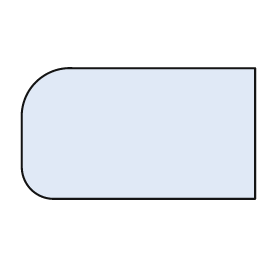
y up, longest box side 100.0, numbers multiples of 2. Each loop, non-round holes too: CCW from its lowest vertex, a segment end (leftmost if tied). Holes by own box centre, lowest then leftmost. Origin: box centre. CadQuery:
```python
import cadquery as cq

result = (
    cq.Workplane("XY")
    .moveTo(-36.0, -28.0)
    .lineTo(50.0, -28.0)
    .lineTo(50.0, 28.0)
    .lineTo(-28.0, 28.0)
    .threePointArc((-44.0, 22.0), (-50.0, 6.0))
    .lineTo(-50.0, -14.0)
    .threePointArc((-46.0, -24.0), (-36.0, -28.0))
    .close()
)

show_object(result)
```